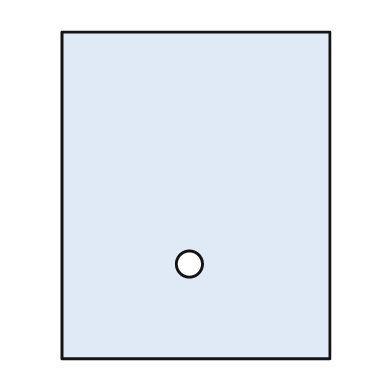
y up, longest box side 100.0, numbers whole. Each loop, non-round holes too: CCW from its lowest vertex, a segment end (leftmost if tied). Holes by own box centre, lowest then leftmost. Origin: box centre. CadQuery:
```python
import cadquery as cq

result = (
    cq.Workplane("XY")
    .moveTo(-41.0, -50.0)
    .lineTo(41.0, -50.0)
    .lineTo(41.0, 50.0)
    .lineTo(-41.0, 50.0)
    .close()
    .moveTo(-2.0, -21.0)
    .circle(4.0)
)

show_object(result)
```